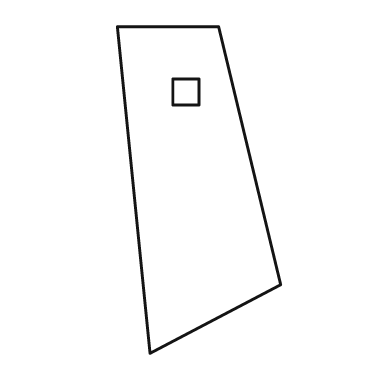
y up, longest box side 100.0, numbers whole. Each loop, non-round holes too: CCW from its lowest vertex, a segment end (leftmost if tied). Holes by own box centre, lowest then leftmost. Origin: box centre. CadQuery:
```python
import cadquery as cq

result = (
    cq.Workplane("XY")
    .moveTo(-15.0, -50.0)
    .lineTo(25.0, -29.0)
    .lineTo(6.0, 50.0)
    .lineTo(-25.0, 50.0)
    .close()
    .moveTo(-8.0, 26.0)
    .lineTo(0.0, 26.0)
    .lineTo(0.0, 34.0)
    .lineTo(-8.0, 34.0)
    .close()
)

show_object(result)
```